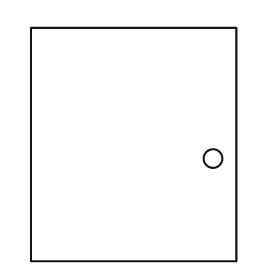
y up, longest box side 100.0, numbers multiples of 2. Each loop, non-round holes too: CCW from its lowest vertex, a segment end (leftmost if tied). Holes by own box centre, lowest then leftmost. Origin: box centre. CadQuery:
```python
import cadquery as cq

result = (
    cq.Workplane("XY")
    .moveTo(-44.0, -50.0)
    .lineTo(44.0, -50.0)
    .lineTo(44.0, 50.0)
    .lineTo(-44.0, 50.0)
    .close()
    .moveTo(34.0, -6.0)
    .circle(4.0)
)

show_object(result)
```